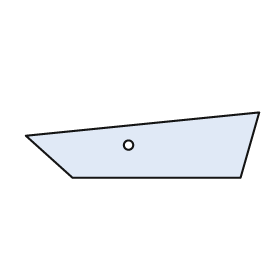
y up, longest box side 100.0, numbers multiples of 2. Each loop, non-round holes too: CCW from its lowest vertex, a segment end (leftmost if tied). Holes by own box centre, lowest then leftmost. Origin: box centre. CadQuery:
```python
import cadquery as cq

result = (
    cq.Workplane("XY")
    .moveTo(-30.0, -14.0)
    .lineTo(42.0, -14.0)
    .lineTo(50.0, 14.0)
    .lineTo(-50.0, 4.0)
    .close()
    .moveTo(-6.0, 0.0)
    .circle(2.0)
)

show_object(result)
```